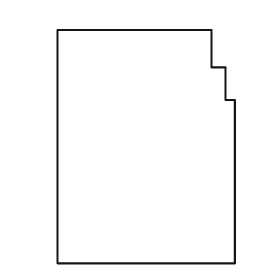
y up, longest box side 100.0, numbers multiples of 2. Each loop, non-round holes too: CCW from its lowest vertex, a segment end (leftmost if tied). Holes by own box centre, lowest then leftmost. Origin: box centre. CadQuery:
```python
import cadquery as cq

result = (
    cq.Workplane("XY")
    .moveTo(-38.0, -50.0)
    .lineTo(38.0, -50.0)
    .lineTo(38.0, 20.0)
    .lineTo(34.0, 20.0)
    .lineTo(34.0, 34.0)
    .lineTo(28.0, 34.0)
    .lineTo(28.0, 50.0)
    .lineTo(-38.0, 50.0)
    .close()
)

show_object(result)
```